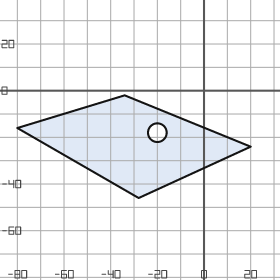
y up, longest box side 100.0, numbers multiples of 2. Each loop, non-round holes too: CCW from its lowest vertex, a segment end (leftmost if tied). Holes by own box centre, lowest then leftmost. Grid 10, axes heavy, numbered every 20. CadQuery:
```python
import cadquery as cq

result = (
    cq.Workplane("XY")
    .moveTo(-28.0, -46.0)
    .lineTo(20.0, -24.0)
    .lineTo(-34.0, -2.0)
    .lineTo(-80.0, -16.0)
    .close()
    .moveTo(-20.0, -18.0)
    .circle(4.0)
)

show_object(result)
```